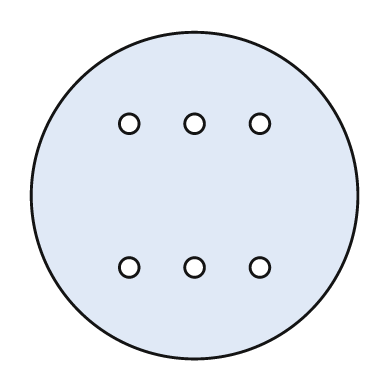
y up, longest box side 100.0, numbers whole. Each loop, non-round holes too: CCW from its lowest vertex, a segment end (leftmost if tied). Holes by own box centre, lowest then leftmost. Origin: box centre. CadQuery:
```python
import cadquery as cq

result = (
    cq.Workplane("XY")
    .moveTo(0.0, 0.0)
    .circle(50.0)
    .moveTo(-20.0, -22.0)
    .circle(3.0)
    .moveTo(0.0, -22.0)
    .circle(3.0)
    .moveTo(20.0, -22.0)
    .circle(3.0)
    .moveTo(-20.0, 22.0)
    .circle(3.0)
    .moveTo(0.0, 22.0)
    .circle(3.0)
    .moveTo(20.0, 22.0)
    .circle(3.0)
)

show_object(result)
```